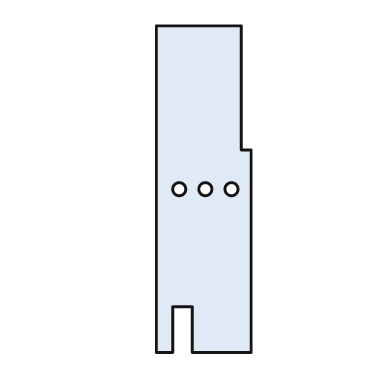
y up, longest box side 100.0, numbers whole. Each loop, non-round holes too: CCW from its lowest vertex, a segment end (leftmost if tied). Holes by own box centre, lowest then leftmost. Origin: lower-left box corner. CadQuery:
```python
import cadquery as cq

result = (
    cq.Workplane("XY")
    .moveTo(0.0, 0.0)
    .lineTo(5.0, 0.0)
    .lineTo(5.0, 14.0)
    .lineTo(11.0, 14.0)
    .lineTo(11.0, 0.0)
    .lineTo(29.0, 0.0)
    .lineTo(29.0, 62.0)
    .lineTo(26.0, 62.0)
    .lineTo(26.0, 100.0)
    .lineTo(0.0, 100.0)
    .close()
    .moveTo(7.0, 50.0)
    .circle(2.0)
    .moveTo(15.0, 50.0)
    .circle(2.0)
    .moveTo(23.0, 50.0)
    .circle(2.0)
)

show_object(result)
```